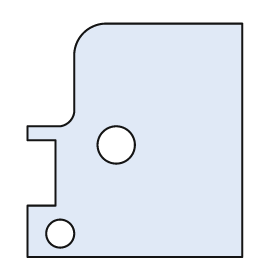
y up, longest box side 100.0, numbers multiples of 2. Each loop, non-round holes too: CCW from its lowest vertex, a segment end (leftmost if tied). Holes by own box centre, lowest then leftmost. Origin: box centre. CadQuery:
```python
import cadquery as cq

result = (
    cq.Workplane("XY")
    .moveTo(-46.0, -50.0)
    .lineTo(46.0, -50.0)
    .lineTo(46.0, 50.0)
    .lineTo(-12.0, 50.0)
    .threePointArc((-22.0, 46.0), (-26.0, 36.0))
    .lineTo(-26.0, 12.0)
    .threePointArc((-28.0, 8.0), (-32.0, 6.0))
    .lineTo(-46.0, 6.0)
    .lineTo(-46.0, 0.0)
    .lineTo(-34.0, 0.0)
    .lineTo(-34.0, -28.0)
    .lineTo(-46.0, -28.0)
    .close()
    .moveTo(-32.0, -40.0)
    .circle(6.0)
    .moveTo(-8.0, -2.0)
    .circle(8.0)
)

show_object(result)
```